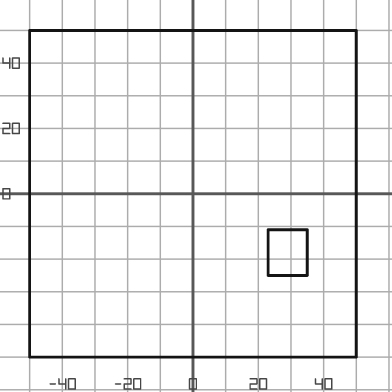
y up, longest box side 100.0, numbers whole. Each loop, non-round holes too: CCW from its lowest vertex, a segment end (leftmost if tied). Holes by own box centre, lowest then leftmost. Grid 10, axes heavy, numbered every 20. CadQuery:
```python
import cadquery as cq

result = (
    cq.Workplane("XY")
    .moveTo(-50.0, -50.0)
    .lineTo(50.0, -50.0)
    .lineTo(50.0, 50.0)
    .lineTo(-50.0, 50.0)
    .close()
    .moveTo(23.0, -25.0)
    .lineTo(35.0, -25.0)
    .lineTo(35.0, -11.0)
    .lineTo(23.0, -11.0)
    .close()
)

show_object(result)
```